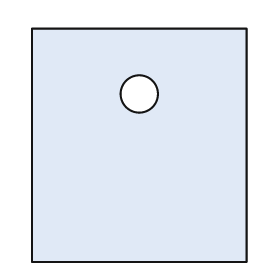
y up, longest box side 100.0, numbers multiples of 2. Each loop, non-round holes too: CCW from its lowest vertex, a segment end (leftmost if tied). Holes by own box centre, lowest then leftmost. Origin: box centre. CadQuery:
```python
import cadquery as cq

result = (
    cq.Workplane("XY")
    .moveTo(-46.0, -50.0)
    .lineTo(46.0, -50.0)
    .lineTo(46.0, 50.0)
    .lineTo(-46.0, 50.0)
    .close()
    .moveTo(0.0, 22.0)
    .circle(8.0)
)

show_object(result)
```